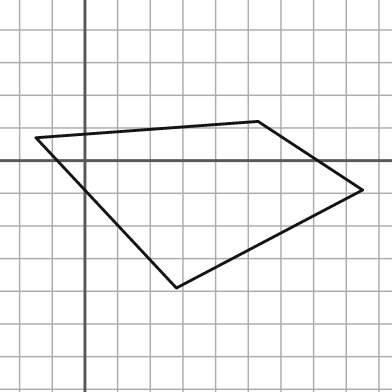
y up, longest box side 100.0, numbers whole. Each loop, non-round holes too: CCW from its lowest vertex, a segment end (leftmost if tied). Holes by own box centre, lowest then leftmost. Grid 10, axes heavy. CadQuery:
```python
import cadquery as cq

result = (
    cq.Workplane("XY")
    .moveTo(28.0, -39.0)
    .lineTo(85.0, -9.0)
    .lineTo(53.0, 12.0)
    .lineTo(-15.0, 7.0)
    .close()
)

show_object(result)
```